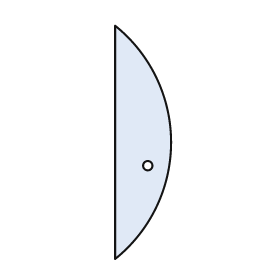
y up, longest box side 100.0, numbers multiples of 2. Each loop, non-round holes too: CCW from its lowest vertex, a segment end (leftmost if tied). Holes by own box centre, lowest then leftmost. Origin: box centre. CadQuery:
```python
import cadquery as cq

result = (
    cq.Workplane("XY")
    .moveTo(-12.0, -50.0)
    .threePointArc((12.0, 0.0), (-12.0, 50.0))
    .close()
    .moveTo(2.0, -10.0)
    .circle(2.0)
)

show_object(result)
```